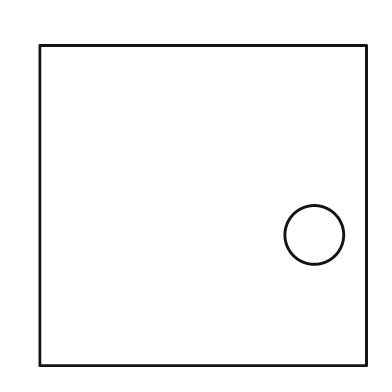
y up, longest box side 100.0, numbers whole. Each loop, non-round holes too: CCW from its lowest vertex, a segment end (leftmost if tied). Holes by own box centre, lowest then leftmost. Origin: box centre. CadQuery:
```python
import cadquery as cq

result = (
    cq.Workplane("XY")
    .moveTo(-50.0, -49.0)
    .lineTo(50.0, -49.0)
    .lineTo(50.0, 49.0)
    .lineTo(-50.0, 49.0)
    .close()
    .moveTo(34.0, -9.0)
    .circle(9.0)
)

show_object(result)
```